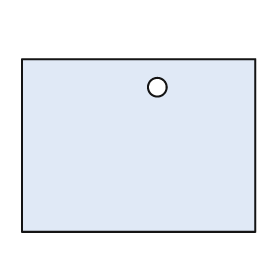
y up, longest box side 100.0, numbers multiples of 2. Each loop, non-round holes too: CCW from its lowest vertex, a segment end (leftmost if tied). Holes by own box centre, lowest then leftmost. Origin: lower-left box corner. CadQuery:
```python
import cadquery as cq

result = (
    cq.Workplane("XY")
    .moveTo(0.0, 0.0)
    .lineTo(100.0, 0.0)
    .lineTo(100.0, 74.0)
    .lineTo(0.0, 74.0)
    .close()
    .moveTo(58.0, 62.0)
    .circle(4.0)
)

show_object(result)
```